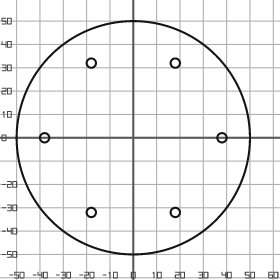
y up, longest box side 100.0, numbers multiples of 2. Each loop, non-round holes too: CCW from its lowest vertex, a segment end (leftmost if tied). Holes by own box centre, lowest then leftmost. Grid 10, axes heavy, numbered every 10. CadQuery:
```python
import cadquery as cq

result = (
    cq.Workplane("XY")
    .moveTo(0.0, 0.0)
    .circle(50.0)
    .moveTo(-18.0, -32.0)
    .circle(2.0)
    .moveTo(18.0, -32.0)
    .circle(2.0)
    .moveTo(-38.0, 0.0)
    .circle(2.0)
    .moveTo(38.0, 0.0)
    .circle(2.0)
    .moveTo(-18.0, 32.0)
    .circle(2.0)
    .moveTo(18.0, 32.0)
    .circle(2.0)
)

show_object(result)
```